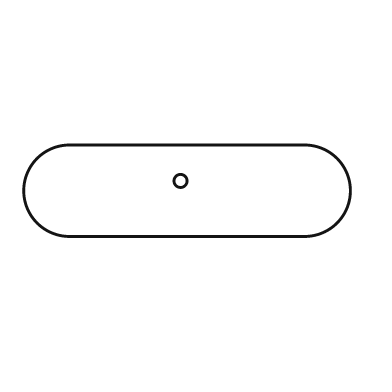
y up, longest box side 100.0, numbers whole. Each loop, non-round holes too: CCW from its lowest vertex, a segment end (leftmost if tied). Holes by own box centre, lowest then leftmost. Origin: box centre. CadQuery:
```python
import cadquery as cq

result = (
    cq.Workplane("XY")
    .moveTo(-36.0, -14.0)
    .lineTo(36.0, -14.0)
    .threePointArc((50.0, 0.0), (36.0, 14.0))
    .lineTo(-36.0, 14.0)
    .threePointArc((-50.0, 0.0), (-36.0, -14.0))
    .close()
    .moveTo(-2.0, 3.0)
    .circle(2.0)
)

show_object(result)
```